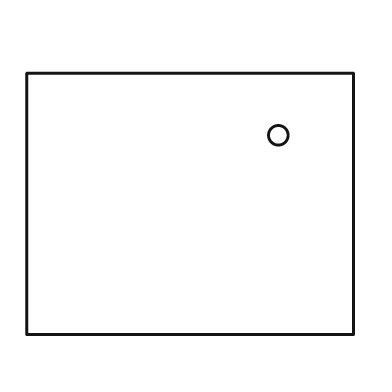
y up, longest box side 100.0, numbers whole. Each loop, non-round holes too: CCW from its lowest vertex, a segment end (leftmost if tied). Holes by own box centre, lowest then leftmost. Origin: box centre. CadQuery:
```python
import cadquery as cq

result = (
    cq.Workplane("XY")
    .moveTo(-50.0, -40.0)
    .lineTo(50.0, -40.0)
    .lineTo(50.0, 40.0)
    .lineTo(-50.0, 40.0)
    .close()
    .moveTo(27.0, 21.0)
    .circle(3.0)
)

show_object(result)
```